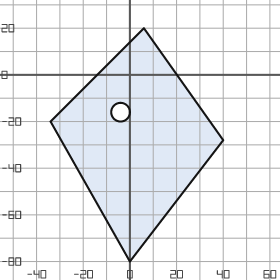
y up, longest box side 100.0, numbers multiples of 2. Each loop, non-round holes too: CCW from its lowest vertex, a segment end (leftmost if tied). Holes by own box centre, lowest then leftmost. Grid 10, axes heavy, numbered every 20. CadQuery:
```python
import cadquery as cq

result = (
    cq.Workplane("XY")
    .moveTo(0.0, -80.0)
    .lineTo(40.0, -28.0)
    .lineTo(6.0, 20.0)
    .lineTo(-34.0, -20.0)
    .close()
    .moveTo(-4.0, -16.0)
    .circle(4.0)
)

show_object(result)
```